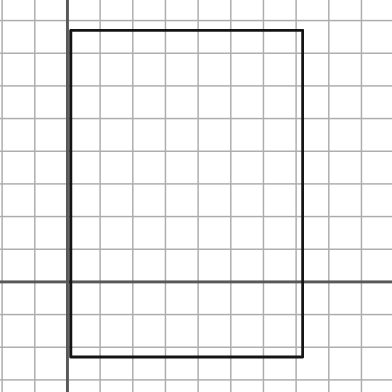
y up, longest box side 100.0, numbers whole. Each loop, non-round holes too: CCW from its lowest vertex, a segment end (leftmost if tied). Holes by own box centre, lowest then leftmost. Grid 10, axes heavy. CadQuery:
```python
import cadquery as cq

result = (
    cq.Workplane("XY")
    .moveTo(1.0, -23.0)
    .lineTo(72.0, -23.0)
    .lineTo(72.0, 77.0)
    .lineTo(1.0, 77.0)
    .close()
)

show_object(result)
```